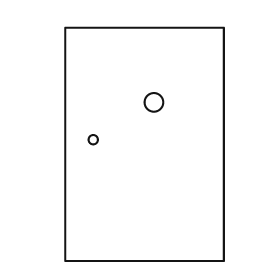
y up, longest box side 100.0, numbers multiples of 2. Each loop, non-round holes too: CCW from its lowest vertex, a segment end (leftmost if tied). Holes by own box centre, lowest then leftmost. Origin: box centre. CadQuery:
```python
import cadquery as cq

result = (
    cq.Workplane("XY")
    .moveTo(-34.0, -50.0)
    .lineTo(34.0, -50.0)
    .lineTo(34.0, 50.0)
    .lineTo(-34.0, 50.0)
    .close()
    .moveTo(-22.0, 2.0)
    .circle(2.0)
    .moveTo(4.0, 18.0)
    .circle(4.0)
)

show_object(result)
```